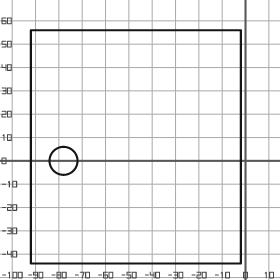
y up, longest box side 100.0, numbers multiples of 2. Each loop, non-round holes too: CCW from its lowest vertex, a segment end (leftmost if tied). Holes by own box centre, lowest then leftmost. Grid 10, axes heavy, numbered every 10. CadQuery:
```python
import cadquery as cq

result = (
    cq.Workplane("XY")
    .moveTo(-92.0, -44.0)
    .lineTo(-2.0, -44.0)
    .lineTo(-2.0, 56.0)
    .lineTo(-92.0, 56.0)
    .close()
    .moveTo(-78.0, 0.0)
    .circle(6.0)
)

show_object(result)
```